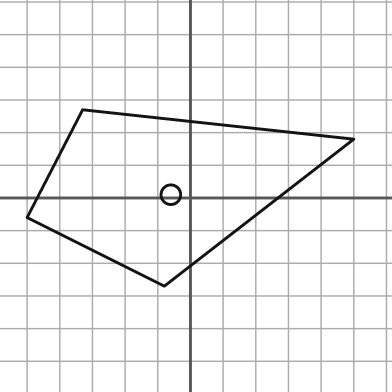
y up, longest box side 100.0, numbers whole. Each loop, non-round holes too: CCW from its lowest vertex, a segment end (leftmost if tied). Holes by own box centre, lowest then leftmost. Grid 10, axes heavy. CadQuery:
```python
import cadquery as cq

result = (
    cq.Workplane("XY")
    .moveTo(-8.0, -27.0)
    .lineTo(50.0, 18.0)
    .lineTo(-33.0, 27.0)
    .lineTo(-50.0, -6.0)
    .close()
    .moveTo(-6.0, 1.0)
    .circle(3.0)
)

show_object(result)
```